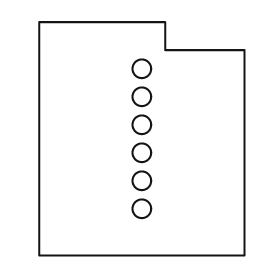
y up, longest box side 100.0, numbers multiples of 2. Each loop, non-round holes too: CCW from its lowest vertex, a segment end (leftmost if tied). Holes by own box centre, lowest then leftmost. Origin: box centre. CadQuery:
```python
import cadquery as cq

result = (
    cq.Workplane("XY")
    .moveTo(-44.0, -50.0)
    .lineTo(44.0, -50.0)
    .lineTo(44.0, 38.0)
    .lineTo(10.0, 38.0)
    .lineTo(10.0, 50.0)
    .lineTo(-44.0, 50.0)
    .close()
    .moveTo(0.0, -30.0)
    .circle(4.0)
    .moveTo(0.0, -18.0)
    .circle(4.0)
    .moveTo(0.0, -6.0)
    .circle(4.0)
    .moveTo(0.0, 6.0)
    .circle(4.0)
    .moveTo(0.0, 18.0)
    .circle(4.0)
    .moveTo(0.0, 30.0)
    .circle(4.0)
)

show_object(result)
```